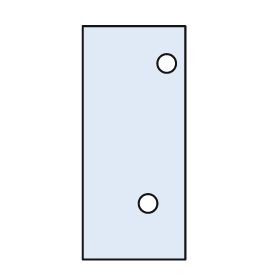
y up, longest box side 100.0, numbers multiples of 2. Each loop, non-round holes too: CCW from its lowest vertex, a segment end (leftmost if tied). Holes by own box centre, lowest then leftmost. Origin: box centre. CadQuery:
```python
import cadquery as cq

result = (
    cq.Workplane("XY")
    .moveTo(-22.0, -50.0)
    .lineTo(22.0, -50.0)
    .lineTo(22.0, 50.0)
    .lineTo(-22.0, 50.0)
    .close()
    .moveTo(6.0, -26.0)
    .circle(4.0)
    .moveTo(14.0, 34.0)
    .circle(4.0)
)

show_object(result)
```